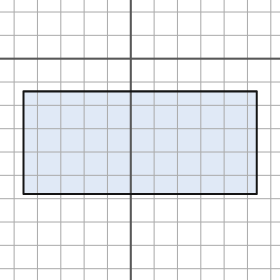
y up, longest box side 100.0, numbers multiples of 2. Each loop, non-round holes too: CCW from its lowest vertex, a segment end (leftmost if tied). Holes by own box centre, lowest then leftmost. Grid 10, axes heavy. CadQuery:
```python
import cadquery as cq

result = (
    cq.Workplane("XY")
    .moveTo(-46.0, -58.0)
    .lineTo(54.0, -58.0)
    .lineTo(54.0, -14.0)
    .lineTo(-46.0, -14.0)
    .close()
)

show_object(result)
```